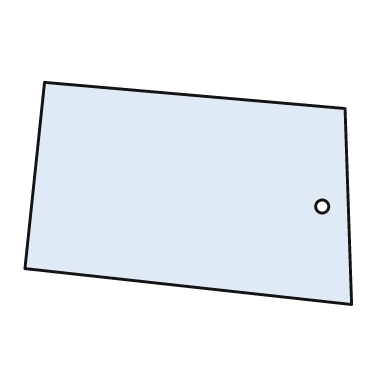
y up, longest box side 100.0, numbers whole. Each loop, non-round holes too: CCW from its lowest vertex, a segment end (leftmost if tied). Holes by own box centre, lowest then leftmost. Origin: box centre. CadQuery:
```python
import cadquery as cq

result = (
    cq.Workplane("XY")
    .moveTo(50.0, -34.0)
    .lineTo(48.0, 26.0)
    .lineTo(-44.0, 34.0)
    .lineTo(-50.0, -23.0)
    .close()
    .moveTo(41.0, -4.0)
    .circle(2.0)
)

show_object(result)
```